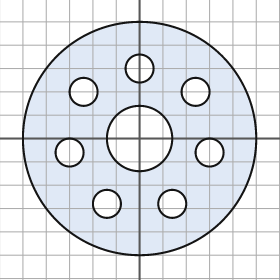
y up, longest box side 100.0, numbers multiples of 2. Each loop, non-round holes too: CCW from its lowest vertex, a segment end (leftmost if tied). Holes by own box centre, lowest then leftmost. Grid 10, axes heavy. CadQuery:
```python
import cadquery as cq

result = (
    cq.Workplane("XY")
    .moveTo(0.0, 0.0)
    .circle(50.0)
    .moveTo(-14.0, -28.0)
    .circle(6.0)
    .moveTo(14.0, -28.0)
    .circle(6.0)
    .moveTo(-30.0, -6.0)
    .circle(6.0)
    .moveTo(30.0, -6.0)
    .circle(6.0)
    .moveTo(0.0, 0.0)
    .circle(14.0)
    .moveTo(-24.0, 20.0)
    .circle(6.0)
    .moveTo(24.0, 20.0)
    .circle(6.0)
    .moveTo(0.0, 30.0)
    .circle(6.0)
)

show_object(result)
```